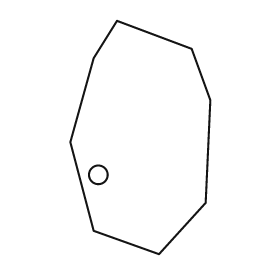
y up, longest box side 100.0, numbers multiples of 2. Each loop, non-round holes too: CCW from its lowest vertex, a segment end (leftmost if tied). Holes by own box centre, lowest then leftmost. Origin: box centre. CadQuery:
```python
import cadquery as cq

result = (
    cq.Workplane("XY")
    .moveTo(8.0, -50.0)
    .lineTo(28.0, -28.0)
    .lineTo(30.0, 16.0)
    .lineTo(22.0, 38.0)
    .lineTo(-10.0, 50.0)
    .lineTo(-20.0, 34.0)
    .lineTo(-30.0, -2.0)
    .lineTo(-20.0, -40.0)
    .close()
    .moveTo(-18.0, -16.0)
    .circle(4.0)
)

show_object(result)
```